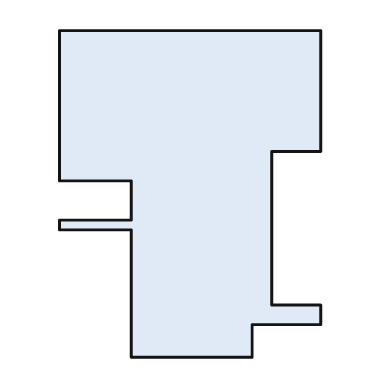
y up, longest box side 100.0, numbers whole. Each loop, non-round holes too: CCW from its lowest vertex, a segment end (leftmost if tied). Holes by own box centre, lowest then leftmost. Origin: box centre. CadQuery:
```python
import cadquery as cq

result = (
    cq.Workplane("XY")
    .moveTo(-18.0, -50.0)
    .lineTo(19.0, -50.0)
    .lineTo(19.0, -40.0)
    .lineTo(40.0, -40.0)
    .lineTo(40.0, -34.0)
    .lineTo(25.0, -34.0)
    .lineTo(25.0, 13.0)
    .lineTo(40.0, 13.0)
    .lineTo(40.0, 50.0)
    .lineTo(-40.0, 50.0)
    .lineTo(-40.0, 4.0)
    .lineTo(-18.0, 4.0)
    .lineTo(-18.0, -8.0)
    .lineTo(-40.0, -8.0)
    .lineTo(-40.0, -11.0)
    .lineTo(-18.0, -11.0)
    .close()
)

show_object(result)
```